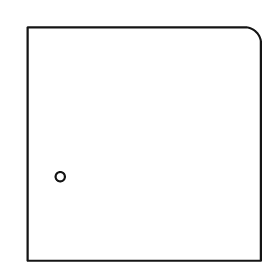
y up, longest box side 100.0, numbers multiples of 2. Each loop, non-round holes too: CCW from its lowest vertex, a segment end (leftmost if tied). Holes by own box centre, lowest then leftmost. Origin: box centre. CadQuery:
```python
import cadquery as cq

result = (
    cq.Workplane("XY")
    .moveTo(-50.0, -50.0)
    .lineTo(50.0, -50.0)
    .lineTo(50.0, 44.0)
    .threePointArc((48.0, 48.0), (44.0, 50.0))
    .lineTo(-50.0, 50.0)
    .close()
    .moveTo(-36.0, -14.0)
    .circle(2.0)
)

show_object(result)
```